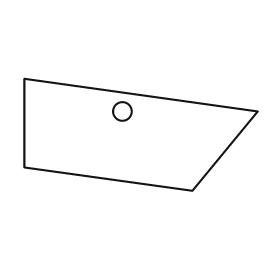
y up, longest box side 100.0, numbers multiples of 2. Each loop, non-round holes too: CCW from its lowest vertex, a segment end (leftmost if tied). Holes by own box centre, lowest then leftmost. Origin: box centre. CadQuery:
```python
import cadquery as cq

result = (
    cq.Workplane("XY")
    .moveTo(22.0, -24.0)
    .lineTo(50.0, 10.0)
    .lineTo(-50.0, 24.0)
    .lineTo(-50.0, -14.0)
    .close()
    .moveTo(-8.0, 10.0)
    .circle(4.0)
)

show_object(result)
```